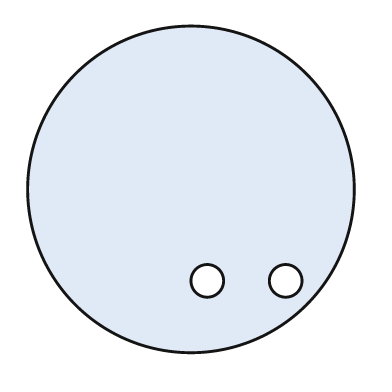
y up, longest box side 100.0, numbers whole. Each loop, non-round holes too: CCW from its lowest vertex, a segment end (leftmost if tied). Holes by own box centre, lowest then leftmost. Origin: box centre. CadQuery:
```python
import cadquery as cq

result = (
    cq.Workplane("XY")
    .moveTo(0.0, 0.0)
    .circle(50.0)
    .moveTo(5.0, -28.0)
    .circle(5.0)
    .moveTo(29.0, -28.0)
    .circle(5.0)
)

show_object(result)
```